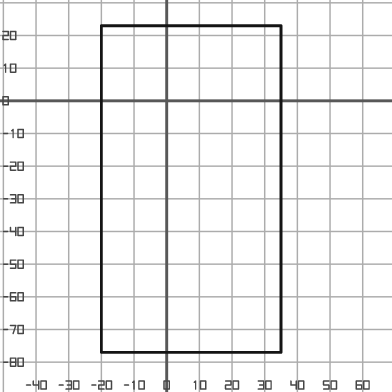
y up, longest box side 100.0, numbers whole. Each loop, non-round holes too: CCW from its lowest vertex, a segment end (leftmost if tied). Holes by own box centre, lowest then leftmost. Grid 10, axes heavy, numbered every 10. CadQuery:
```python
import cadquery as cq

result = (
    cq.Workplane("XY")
    .moveTo(-20.0, -77.0)
    .lineTo(35.0, -77.0)
    .lineTo(35.0, 23.0)
    .lineTo(-20.0, 23.0)
    .close()
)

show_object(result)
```